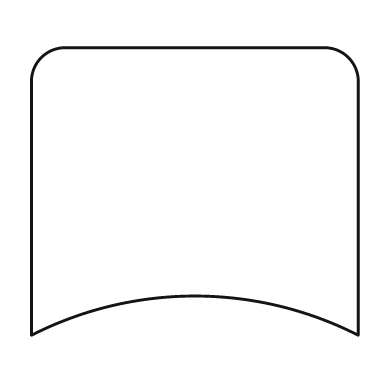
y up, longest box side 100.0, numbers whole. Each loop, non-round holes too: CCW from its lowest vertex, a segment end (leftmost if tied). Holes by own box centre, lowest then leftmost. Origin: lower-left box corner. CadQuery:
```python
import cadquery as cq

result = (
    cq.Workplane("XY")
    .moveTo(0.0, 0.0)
    .threePointArc((50.0, 12.0), (100.0, 0.0))
    .lineTo(100.0, 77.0)
    .threePointArc((97.0, 85.0), (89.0, 88.0))
    .lineTo(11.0, 88.0)
    .threePointArc((3.0, 85.0), (0.0, 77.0))
    .close()
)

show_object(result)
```